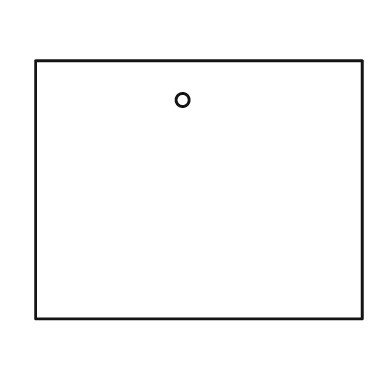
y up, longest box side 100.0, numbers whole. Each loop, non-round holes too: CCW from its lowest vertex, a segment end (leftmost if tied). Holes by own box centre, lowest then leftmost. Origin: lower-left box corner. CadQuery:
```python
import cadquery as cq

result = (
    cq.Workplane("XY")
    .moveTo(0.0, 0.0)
    .lineTo(100.0, 0.0)
    .lineTo(100.0, 79.0)
    .lineTo(0.0, 79.0)
    .close()
    .moveTo(45.0, 67.0)
    .circle(2.0)
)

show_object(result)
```